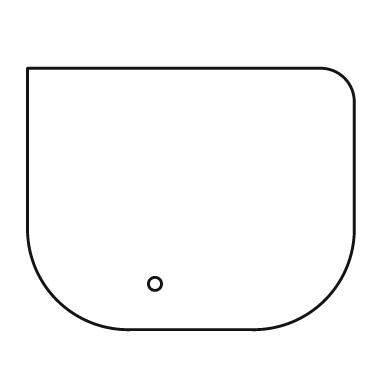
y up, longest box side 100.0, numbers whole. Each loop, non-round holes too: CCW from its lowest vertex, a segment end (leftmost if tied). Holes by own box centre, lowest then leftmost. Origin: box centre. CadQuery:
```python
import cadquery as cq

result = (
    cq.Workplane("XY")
    .moveTo(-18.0, -40.0)
    .lineTo(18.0, -40.0)
    .threePointArc((41.0, -31.0), (50.0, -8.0))
    .lineTo(50.0, 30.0)
    .threePointArc((47.0, 37.0), (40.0, 40.0))
    .lineTo(-50.0, 40.0)
    .lineTo(-50.0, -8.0)
    .threePointArc((-41.0, -31.0), (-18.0, -40.0))
    .close()
    .moveTo(-11.0, -26.0)
    .circle(2.0)
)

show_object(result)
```